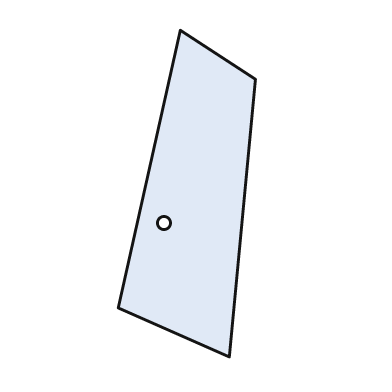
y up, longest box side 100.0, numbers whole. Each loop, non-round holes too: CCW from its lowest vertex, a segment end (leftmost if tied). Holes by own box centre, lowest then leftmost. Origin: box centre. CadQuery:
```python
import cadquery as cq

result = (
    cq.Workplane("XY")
    .moveTo(13.0, -50.0)
    .lineTo(21.0, 35.0)
    .lineTo(-2.0, 50.0)
    .lineTo(-21.0, -35.0)
    .close()
    .moveTo(-7.0, -9.0)
    .circle(2.0)
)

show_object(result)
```